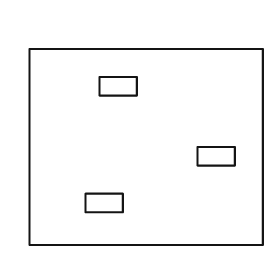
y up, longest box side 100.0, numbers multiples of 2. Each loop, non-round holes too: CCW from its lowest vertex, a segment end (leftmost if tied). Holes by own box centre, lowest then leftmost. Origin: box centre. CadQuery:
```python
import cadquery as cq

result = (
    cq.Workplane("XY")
    .moveTo(-50.0, -42.0)
    .lineTo(50.0, -42.0)
    .lineTo(50.0, 42.0)
    .lineTo(-50.0, 42.0)
    .close()
    .moveTo(-26.0, -28.0)
    .lineTo(-10.0, -28.0)
    .lineTo(-10.0, -20.0)
    .lineTo(-26.0, -20.0)
    .close()
    .moveTo(22.0, -8.0)
    .lineTo(38.0, -8.0)
    .lineTo(38.0, 0.0)
    .lineTo(22.0, 0.0)
    .close()
    .moveTo(-20.0, 22.0)
    .lineTo(-4.0, 22.0)
    .lineTo(-4.0, 30.0)
    .lineTo(-20.0, 30.0)
    .close()
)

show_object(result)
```